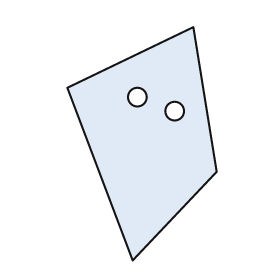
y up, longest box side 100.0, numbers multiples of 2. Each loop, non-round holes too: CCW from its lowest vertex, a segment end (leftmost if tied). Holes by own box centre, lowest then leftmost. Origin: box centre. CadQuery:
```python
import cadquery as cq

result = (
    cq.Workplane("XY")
    .moveTo(-4.0, -50.0)
    .lineTo(32.0, -12.0)
    .lineTo(22.0, 50.0)
    .lineTo(-32.0, 24.0)
    .close()
    .moveTo(14.0, 14.0)
    .circle(4.0)
    .moveTo(-2.0, 20.0)
    .circle(4.0)
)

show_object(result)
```